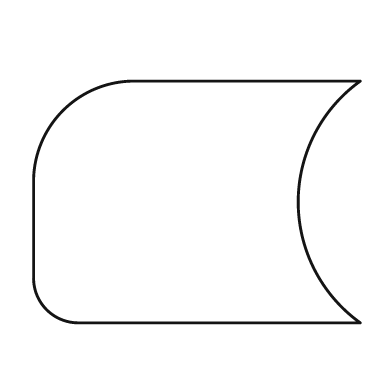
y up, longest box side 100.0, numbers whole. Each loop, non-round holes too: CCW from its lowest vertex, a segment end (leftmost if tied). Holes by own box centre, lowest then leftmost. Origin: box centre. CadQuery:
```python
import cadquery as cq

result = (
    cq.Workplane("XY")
    .moveTo(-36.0, -37.0)
    .lineTo(50.0, -37.0)
    .threePointArc((31.0, 0.0), (50.0, 37.0))
    .lineTo(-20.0, 37.0)
    .threePointArc((-41.0, 28.0), (-50.0, 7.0))
    .lineTo(-50.0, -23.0)
    .threePointArc((-46.0, -33.0), (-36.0, -37.0))
    .close()
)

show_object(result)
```